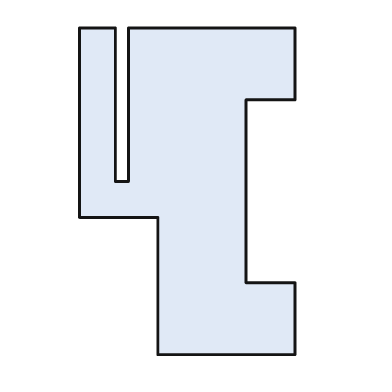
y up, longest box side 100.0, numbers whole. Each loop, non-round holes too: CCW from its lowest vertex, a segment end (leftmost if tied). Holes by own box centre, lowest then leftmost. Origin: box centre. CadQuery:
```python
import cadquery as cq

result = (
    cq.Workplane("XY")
    .moveTo(-9.0, -50.0)
    .lineTo(33.0, -50.0)
    .lineTo(33.0, -28.0)
    .lineTo(18.0, -28.0)
    .lineTo(18.0, 28.0)
    .lineTo(33.0, 28.0)
    .lineTo(33.0, 50.0)
    .lineTo(-18.0, 50.0)
    .lineTo(-18.0, 3.0)
    .lineTo(-22.0, 3.0)
    .lineTo(-22.0, 50.0)
    .lineTo(-33.0, 50.0)
    .lineTo(-33.0, -8.0)
    .lineTo(-9.0, -8.0)
    .close()
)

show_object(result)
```